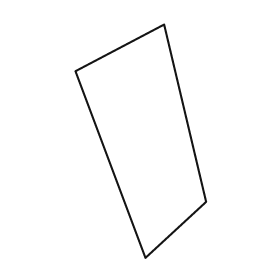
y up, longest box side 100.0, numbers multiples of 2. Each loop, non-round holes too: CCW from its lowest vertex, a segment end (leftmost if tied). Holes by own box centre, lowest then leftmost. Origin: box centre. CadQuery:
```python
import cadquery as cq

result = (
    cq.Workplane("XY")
    .moveTo(2.0, -50.0)
    .lineTo(28.0, -26.0)
    .lineTo(10.0, 50.0)
    .lineTo(-28.0, 30.0)
    .close()
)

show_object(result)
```